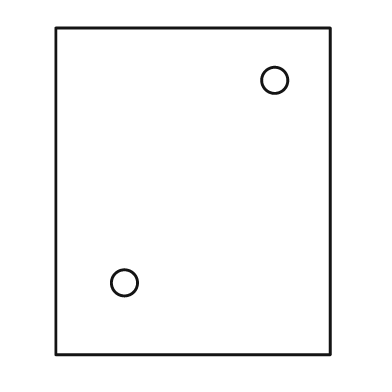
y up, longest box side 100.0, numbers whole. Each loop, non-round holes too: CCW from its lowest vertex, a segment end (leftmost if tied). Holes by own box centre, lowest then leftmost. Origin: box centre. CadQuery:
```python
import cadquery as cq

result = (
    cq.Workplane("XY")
    .moveTo(-42.0, -50.0)
    .lineTo(42.0, -50.0)
    .lineTo(42.0, 50.0)
    .lineTo(-42.0, 50.0)
    .close()
    .moveTo(-21.0, -28.0)
    .circle(4.0)
    .moveTo(25.0, 34.0)
    .circle(4.0)
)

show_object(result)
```